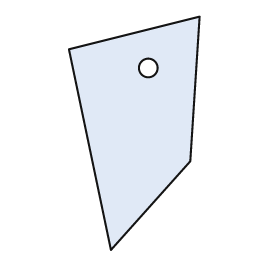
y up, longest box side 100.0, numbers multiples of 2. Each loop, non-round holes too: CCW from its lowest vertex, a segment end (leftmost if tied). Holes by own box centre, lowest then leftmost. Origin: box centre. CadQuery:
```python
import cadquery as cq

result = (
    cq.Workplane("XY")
    .moveTo(-10.0, -50.0)
    .lineTo(24.0, -12.0)
    .lineTo(28.0, 50.0)
    .lineTo(-28.0, 36.0)
    .close()
    .moveTo(6.0, 28.0)
    .circle(4.0)
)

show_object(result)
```